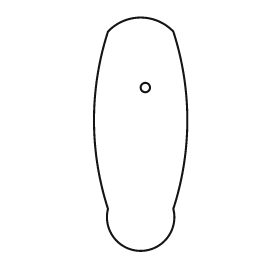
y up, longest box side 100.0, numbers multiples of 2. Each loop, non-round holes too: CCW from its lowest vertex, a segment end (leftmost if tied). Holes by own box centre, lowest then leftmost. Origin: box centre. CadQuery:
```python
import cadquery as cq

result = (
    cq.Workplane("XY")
    .moveTo(-14.0, -32.0)
    .threePointArc((0.0, -50.0), (14.0, -32.0))
    .threePointArc((20.0, 6.0), (14.0, 44.0))
    .threePointArc((0.0, 50.0), (-14.0, 44.0))
    .threePointArc((-20.0, 6.0), (-14.0, -32.0))
    .close()
    .moveTo(2.0, 20.0)
    .circle(2.0)
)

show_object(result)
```